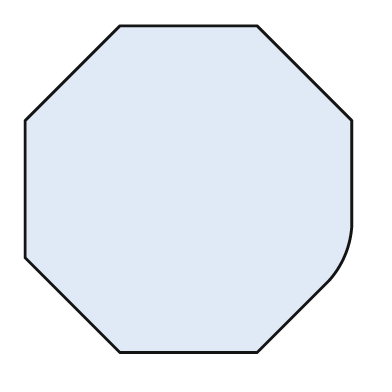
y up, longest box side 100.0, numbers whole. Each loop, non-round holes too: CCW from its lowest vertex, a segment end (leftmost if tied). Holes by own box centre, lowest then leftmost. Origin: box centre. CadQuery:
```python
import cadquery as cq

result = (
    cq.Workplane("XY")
    .moveTo(-21.0, -50.0)
    .lineTo(21.0, -50.0)
    .lineTo(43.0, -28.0)
    .threePointArc((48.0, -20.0), (50.0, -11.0))
    .lineTo(50.0, 21.0)
    .lineTo(21.0, 50.0)
    .lineTo(-21.0, 50.0)
    .lineTo(-50.0, 21.0)
    .lineTo(-50.0, -21.0)
    .close()
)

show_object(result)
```